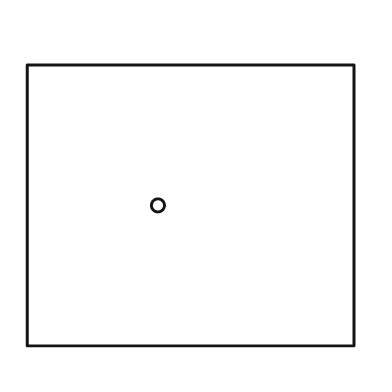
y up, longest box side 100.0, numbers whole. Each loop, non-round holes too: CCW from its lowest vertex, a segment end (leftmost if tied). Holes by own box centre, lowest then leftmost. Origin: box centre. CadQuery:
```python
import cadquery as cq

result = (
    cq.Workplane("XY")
    .moveTo(-50.0, -43.0)
    .lineTo(50.0, -43.0)
    .lineTo(50.0, 43.0)
    .lineTo(-50.0, 43.0)
    .close()
    .moveTo(-10.0, 0.0)
    .circle(2.0)
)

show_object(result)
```